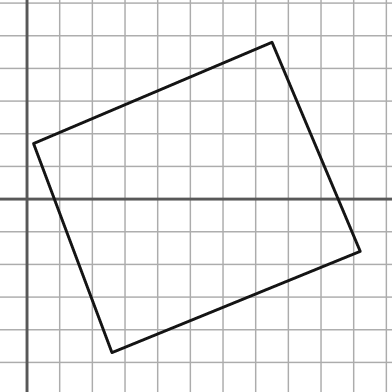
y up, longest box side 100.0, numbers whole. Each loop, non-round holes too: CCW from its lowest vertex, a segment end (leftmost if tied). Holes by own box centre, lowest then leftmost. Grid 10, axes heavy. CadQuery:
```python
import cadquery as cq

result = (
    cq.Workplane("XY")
    .moveTo(26.0, -47.0)
    .lineTo(102.0, -16.0)
    .lineTo(75.0, 48.0)
    .lineTo(2.0, 17.0)
    .close()
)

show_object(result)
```